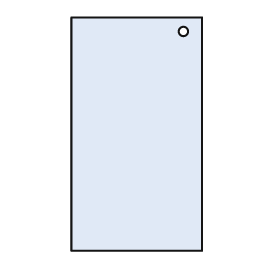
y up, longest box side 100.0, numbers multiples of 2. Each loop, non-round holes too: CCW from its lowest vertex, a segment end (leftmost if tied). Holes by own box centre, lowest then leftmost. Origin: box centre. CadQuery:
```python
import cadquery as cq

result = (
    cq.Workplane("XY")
    .moveTo(-28.0, -50.0)
    .lineTo(28.0, -50.0)
    .lineTo(28.0, 50.0)
    .lineTo(-28.0, 50.0)
    .close()
    .moveTo(20.0, 44.0)
    .circle(2.0)
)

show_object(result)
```